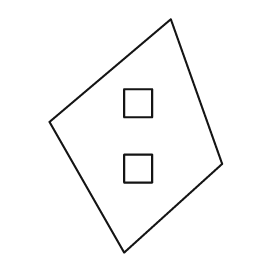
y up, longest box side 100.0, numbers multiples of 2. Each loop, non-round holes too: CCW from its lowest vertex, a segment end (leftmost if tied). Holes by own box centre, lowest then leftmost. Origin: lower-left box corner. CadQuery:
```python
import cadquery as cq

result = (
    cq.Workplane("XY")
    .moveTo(32.0, 0.0)
    .lineTo(74.0, 38.0)
    .lineTo(52.0, 100.0)
    .lineTo(0.0, 56.0)
    .close()
    .moveTo(32.0, 30.0)
    .lineTo(44.0, 30.0)
    .lineTo(44.0, 42.0)
    .lineTo(32.0, 42.0)
    .close()
    .moveTo(32.0, 58.0)
    .lineTo(44.0, 58.0)
    .lineTo(44.0, 70.0)
    .lineTo(32.0, 70.0)
    .close()
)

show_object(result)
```